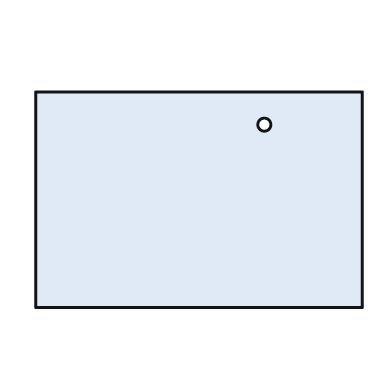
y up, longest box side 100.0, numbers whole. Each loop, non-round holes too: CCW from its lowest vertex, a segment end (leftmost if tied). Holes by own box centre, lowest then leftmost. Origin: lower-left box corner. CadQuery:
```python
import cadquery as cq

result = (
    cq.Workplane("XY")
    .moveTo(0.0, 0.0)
    .lineTo(100.0, 0.0)
    .lineTo(100.0, 66.0)
    .lineTo(0.0, 66.0)
    .close()
    .moveTo(70.0, 56.0)
    .circle(2.0)
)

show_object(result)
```